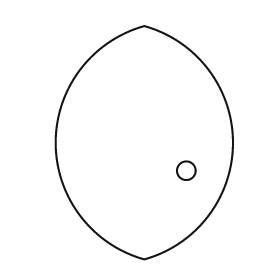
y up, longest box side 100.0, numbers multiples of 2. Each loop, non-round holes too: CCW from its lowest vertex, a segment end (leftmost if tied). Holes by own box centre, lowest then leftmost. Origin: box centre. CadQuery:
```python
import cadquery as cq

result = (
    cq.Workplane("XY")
    .moveTo(0.0, -50.0)
    .threePointArc((38.0, 0.0), (0.0, 50.0))
    .threePointArc((-38.0, 0.0), (0.0, -50.0))
    .close()
    .moveTo(18.0, -12.0)
    .circle(4.0)
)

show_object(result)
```